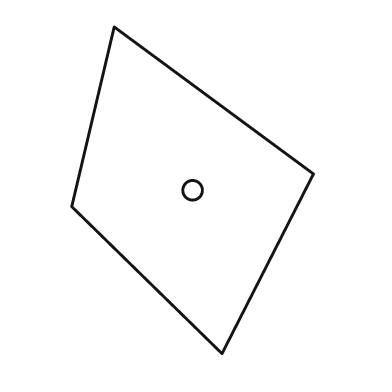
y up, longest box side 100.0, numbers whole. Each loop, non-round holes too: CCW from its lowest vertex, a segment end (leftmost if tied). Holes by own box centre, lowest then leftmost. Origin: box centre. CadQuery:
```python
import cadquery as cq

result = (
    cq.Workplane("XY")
    .moveTo(9.0, -50.0)
    .lineTo(37.0, 5.0)
    .lineTo(-24.0, 50.0)
    .lineTo(-37.0, -5.0)
    .close()
    .moveTo(0.0, 0.0)
    .circle(3.0)
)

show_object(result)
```